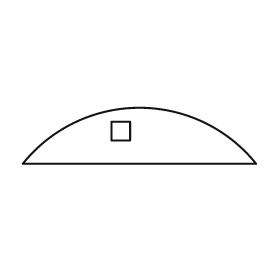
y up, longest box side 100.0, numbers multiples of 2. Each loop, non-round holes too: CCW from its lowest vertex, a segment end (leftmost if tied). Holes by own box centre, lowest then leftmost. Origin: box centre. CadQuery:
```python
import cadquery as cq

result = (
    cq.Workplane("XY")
    .moveTo(-50.0, -12.0)
    .lineTo(50.0, -12.0)
    .threePointArc((0.0, 12.0), (-50.0, -12.0))
    .close()
    .moveTo(-12.0, -2.0)
    .lineTo(-4.0, -2.0)
    .lineTo(-4.0, 6.0)
    .lineTo(-12.0, 6.0)
    .close()
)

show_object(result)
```